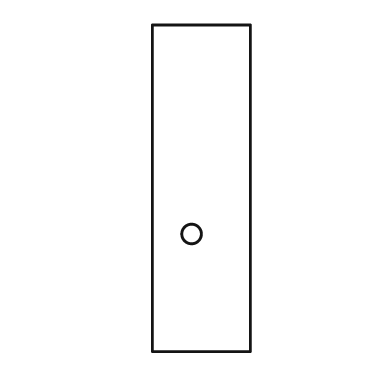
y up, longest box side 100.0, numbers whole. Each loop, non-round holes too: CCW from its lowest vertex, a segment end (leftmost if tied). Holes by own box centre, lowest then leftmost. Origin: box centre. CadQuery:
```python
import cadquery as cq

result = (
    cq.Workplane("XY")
    .moveTo(-15.0, -50.0)
    .lineTo(15.0, -50.0)
    .lineTo(15.0, 50.0)
    .lineTo(-15.0, 50.0)
    .close()
    .moveTo(-3.0, -14.0)
    .circle(3.0)
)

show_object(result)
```